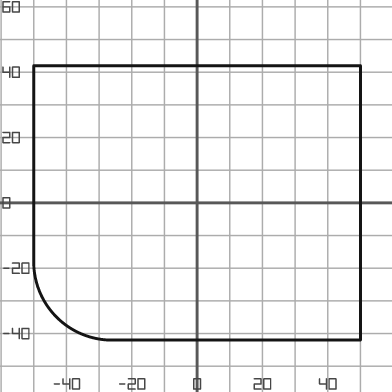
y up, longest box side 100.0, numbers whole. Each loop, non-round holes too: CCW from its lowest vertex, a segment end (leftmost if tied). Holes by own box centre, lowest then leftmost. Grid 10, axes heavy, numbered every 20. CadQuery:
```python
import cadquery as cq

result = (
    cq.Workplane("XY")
    .moveTo(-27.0, -42.0)
    .lineTo(50.0, -42.0)
    .lineTo(50.0, 42.0)
    .lineTo(-50.0, 42.0)
    .lineTo(-50.0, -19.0)
    .threePointArc((-43.0, -35.0), (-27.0, -42.0))
    .close()
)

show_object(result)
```